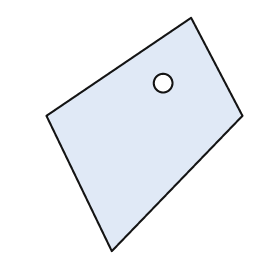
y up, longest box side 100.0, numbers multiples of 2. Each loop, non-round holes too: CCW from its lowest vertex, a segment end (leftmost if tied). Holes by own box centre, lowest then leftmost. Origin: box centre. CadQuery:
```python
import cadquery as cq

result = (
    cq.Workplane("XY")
    .moveTo(-14.0, -50.0)
    .lineTo(42.0, 8.0)
    .lineTo(20.0, 50.0)
    .lineTo(-42.0, 8.0)
    .close()
    .moveTo(8.0, 22.0)
    .circle(4.0)
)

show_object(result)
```